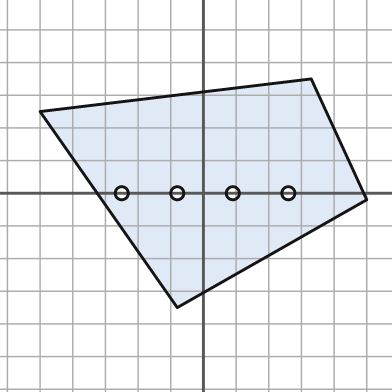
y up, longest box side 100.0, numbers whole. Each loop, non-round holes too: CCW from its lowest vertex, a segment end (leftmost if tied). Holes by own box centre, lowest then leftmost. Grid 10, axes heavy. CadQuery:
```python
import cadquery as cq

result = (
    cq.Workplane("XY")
    .moveTo(-8.0, -35.0)
    .lineTo(50.0, -2.0)
    .lineTo(33.0, 35.0)
    .lineTo(-50.0, 25.0)
    .close()
    .moveTo(-25.0, 0.0)
    .circle(2.0)
    .moveTo(-8.0, 0.0)
    .circle(2.0)
    .moveTo(9.0, 0.0)
    .circle(2.0)
    .moveTo(26.0, 0.0)
    .circle(2.0)
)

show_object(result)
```